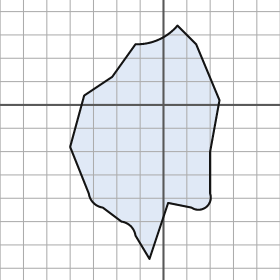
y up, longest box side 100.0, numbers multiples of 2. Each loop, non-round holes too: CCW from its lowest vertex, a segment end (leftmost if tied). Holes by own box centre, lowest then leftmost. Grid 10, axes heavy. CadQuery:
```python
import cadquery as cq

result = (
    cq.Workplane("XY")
    .moveTo(-6.0, -66.0)
    .lineTo(2.0, -42.0)
    .lineTo(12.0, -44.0)
    .threePointArc((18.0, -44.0), (20.0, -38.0))
    .lineTo(20.0, -20.0)
    .lineTo(24.0, 2.0)
    .lineTo(14.0, 26.0)
    .lineTo(6.0, 34.0)
    .threePointArc((-2.0, 28.0), (-12.0, 26.0))
    .lineTo(-22.0, 12.0)
    .lineTo(-34.0, 4.0)
    .lineTo(-40.0, -18.0)
    .lineTo(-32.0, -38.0)
    .threePointArc((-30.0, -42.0), (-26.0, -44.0))
    .lineTo(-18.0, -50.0)
    .threePointArc((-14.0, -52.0), (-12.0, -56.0))
    .close()
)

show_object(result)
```